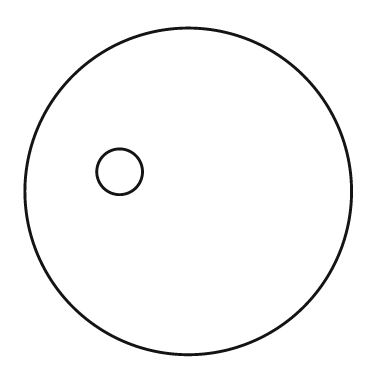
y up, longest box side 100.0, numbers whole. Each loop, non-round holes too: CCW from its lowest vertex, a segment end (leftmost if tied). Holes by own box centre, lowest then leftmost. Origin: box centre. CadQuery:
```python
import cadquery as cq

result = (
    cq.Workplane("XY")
    .moveTo(0.0, 0.0)
    .circle(50.0)
    .moveTo(-21.0, 6.0)
    .circle(7.0)
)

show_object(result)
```